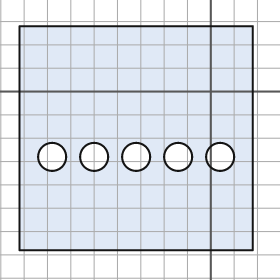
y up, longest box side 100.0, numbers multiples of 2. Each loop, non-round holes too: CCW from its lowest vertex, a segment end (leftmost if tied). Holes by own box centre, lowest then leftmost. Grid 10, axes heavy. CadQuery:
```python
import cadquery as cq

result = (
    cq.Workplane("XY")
    .moveTo(-82.0, -68.0)
    .lineTo(18.0, -68.0)
    .lineTo(18.0, 28.0)
    .lineTo(-82.0, 28.0)
    .close()
    .moveTo(-68.0, -28.0)
    .circle(6.0)
    .moveTo(-50.0, -28.0)
    .circle(6.0)
    .moveTo(-32.0, -28.0)
    .circle(6.0)
    .moveTo(-14.0, -28.0)
    .circle(6.0)
    .moveTo(4.0, -28.0)
    .circle(6.0)
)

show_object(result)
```